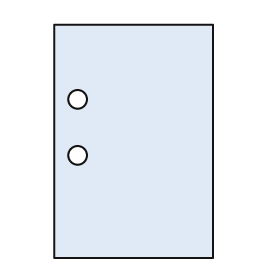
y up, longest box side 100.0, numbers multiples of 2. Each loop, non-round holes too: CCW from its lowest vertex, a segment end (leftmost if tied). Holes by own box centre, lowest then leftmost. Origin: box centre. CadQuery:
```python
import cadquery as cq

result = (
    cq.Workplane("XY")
    .moveTo(-34.0, -50.0)
    .lineTo(34.0, -50.0)
    .lineTo(34.0, 50.0)
    .lineTo(-34.0, 50.0)
    .close()
    .moveTo(-24.0, -6.0)
    .circle(4.0)
    .moveTo(-24.0, 18.0)
    .circle(4.0)
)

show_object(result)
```